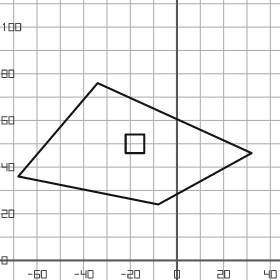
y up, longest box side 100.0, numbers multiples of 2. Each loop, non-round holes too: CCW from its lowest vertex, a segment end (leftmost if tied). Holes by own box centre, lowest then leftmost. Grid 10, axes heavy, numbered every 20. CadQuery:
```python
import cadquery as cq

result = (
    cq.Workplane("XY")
    .moveTo(-8.0, 24.0)
    .lineTo(32.0, 46.0)
    .lineTo(-34.0, 76.0)
    .lineTo(-68.0, 36.0)
    .close()
    .moveTo(-22.0, 46.0)
    .lineTo(-14.0, 46.0)
    .lineTo(-14.0, 54.0)
    .lineTo(-22.0, 54.0)
    .close()
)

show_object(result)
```